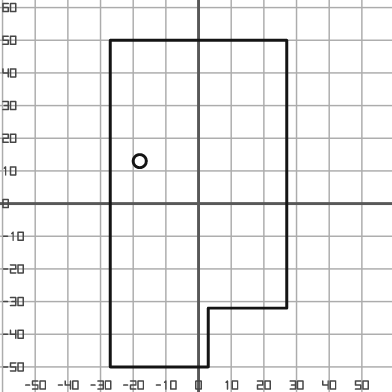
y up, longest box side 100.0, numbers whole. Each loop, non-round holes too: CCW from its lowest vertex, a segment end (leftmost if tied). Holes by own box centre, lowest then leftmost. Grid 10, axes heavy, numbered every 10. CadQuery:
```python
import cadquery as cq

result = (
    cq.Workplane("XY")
    .moveTo(-27.0, -50.0)
    .lineTo(3.0, -50.0)
    .lineTo(3.0, -32.0)
    .lineTo(27.0, -32.0)
    .lineTo(27.0, 50.0)
    .lineTo(-27.0, 50.0)
    .close()
    .moveTo(-18.0, 13.0)
    .circle(2.0)
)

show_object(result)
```